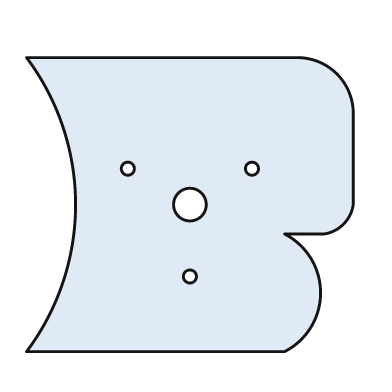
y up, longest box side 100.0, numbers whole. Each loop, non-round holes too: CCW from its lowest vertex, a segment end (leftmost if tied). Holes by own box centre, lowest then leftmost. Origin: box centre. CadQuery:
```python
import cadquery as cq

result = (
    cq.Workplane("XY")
    .moveTo(-50.0, -45.0)
    .lineTo(29.0, -45.0)
    .threePointArc((40.0, -27.0), (29.0, -9.0))
    .lineTo(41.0, -9.0)
    .threePointArc((47.0, -6.0), (50.0, 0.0))
    .lineTo(50.0, 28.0)
    .threePointArc((45.0, 40.0), (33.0, 45.0))
    .lineTo(-50.0, 45.0)
    .threePointArc((-35.0, 0.0), (-50.0, -45.0))
    .close()
    .moveTo(0.0, -22.0)
    .circle(2.0)
    .moveTo(0.0, 0.0)
    .circle(5.0)
    .moveTo(-19.0, 11.0)
    .circle(2.0)
    .moveTo(19.0, 11.0)
    .circle(2.0)
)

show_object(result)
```